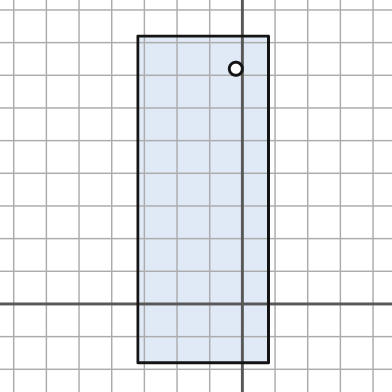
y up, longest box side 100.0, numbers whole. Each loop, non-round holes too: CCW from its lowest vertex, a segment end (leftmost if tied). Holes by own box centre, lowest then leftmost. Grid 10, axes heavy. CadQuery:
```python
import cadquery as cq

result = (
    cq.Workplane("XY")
    .moveTo(-32.0, -18.0)
    .lineTo(8.0, -18.0)
    .lineTo(8.0, 82.0)
    .lineTo(-32.0, 82.0)
    .close()
    .moveTo(-2.0, 72.0)
    .circle(2.0)
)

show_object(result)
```